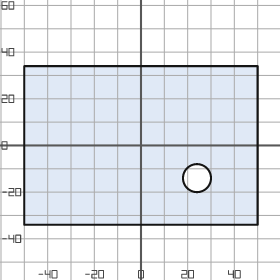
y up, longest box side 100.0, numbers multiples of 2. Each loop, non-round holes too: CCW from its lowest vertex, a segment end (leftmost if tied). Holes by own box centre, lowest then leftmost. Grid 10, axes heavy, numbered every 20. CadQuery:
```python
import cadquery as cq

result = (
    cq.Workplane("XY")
    .moveTo(-50.0, -34.0)
    .lineTo(50.0, -34.0)
    .lineTo(50.0, 34.0)
    .lineTo(-50.0, 34.0)
    .close()
    .moveTo(24.0, -14.0)
    .circle(6.0)
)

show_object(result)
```